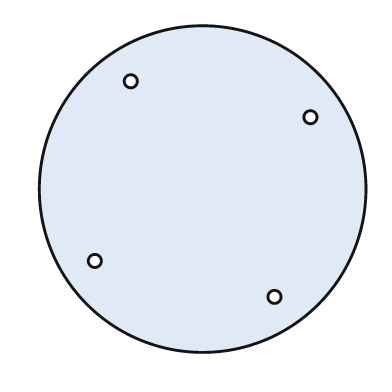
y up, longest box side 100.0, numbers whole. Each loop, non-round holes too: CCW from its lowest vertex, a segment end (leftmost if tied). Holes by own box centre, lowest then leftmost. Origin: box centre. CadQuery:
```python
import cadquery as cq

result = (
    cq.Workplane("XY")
    .moveTo(0.0, 0.0)
    .circle(50.0)
    .moveTo(22.0, -33.0)
    .circle(2.0)
    .moveTo(-33.0, -22.0)
    .circle(2.0)
    .moveTo(33.0, 22.0)
    .circle(2.0)
    .moveTo(-22.0, 33.0)
    .circle(2.0)
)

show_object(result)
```